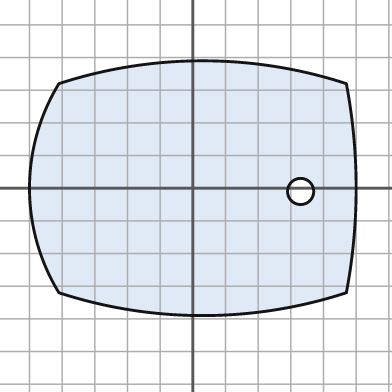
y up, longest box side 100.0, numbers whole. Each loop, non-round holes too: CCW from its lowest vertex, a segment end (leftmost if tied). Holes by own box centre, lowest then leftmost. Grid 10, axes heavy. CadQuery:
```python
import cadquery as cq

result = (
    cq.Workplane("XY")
    .moveTo(-41.0, -32.0)
    .threePointArc((3.0, -39.0), (47.0, -32.0))
    .threePointArc((50.0, 0.0), (47.0, 32.0))
    .threePointArc((3.0, 39.0), (-41.0, 32.0))
    .threePointArc((-50.0, 0.0), (-41.0, -32.0))
    .close()
    .moveTo(33.0, -1.0)
    .circle(4.0)
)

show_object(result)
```